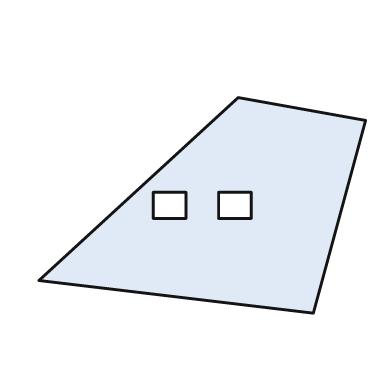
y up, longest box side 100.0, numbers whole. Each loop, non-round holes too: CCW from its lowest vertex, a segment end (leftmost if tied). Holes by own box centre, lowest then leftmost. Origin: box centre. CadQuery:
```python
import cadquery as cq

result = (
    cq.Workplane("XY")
    .moveTo(34.0, -33.0)
    .lineTo(50.0, 26.0)
    .lineTo(11.0, 33.0)
    .lineTo(-50.0, -23.0)
    .close()
    .moveTo(-15.0, -4.0)
    .lineTo(-5.0, -4.0)
    .lineTo(-5.0, 4.0)
    .lineTo(-15.0, 4.0)
    .close()
    .moveTo(5.0, -4.0)
    .lineTo(15.0, -4.0)
    .lineTo(15.0, 4.0)
    .lineTo(5.0, 4.0)
    .close()
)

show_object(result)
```